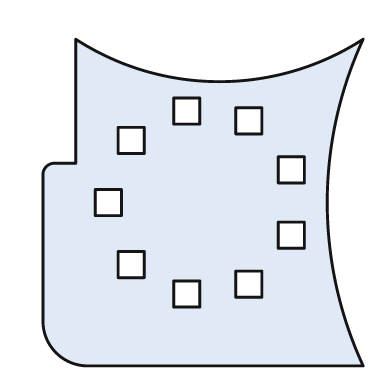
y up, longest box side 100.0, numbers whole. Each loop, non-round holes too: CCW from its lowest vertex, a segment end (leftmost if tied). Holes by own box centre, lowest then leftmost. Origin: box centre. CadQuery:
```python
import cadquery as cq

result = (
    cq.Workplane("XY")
    .moveTo(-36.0, -50.0)
    .lineTo(49.0, -50.0)
    .threePointArc((38.0, 0.0), (49.0, 50.0))
    .threePointArc((5.0, 37.0), (-39.0, 50.0))
    .lineTo(-39.0, 12.0)
    .lineTo(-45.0, 12.0)
    .threePointArc((-48.0, 11.0), (-49.0, 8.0))
    .lineTo(-49.0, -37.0)
    .threePointArc((-45.0, -46.0), (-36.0, -50.0))
    .close()
    .moveTo(-9.0, -32.0)
    .lineTo(-1.0, -32.0)
    .lineTo(-1.0, -24.0)
    .lineTo(-9.0, -24.0)
    .close()
    .moveTo(10.0, -29.0)
    .lineTo(18.0, -29.0)
    .lineTo(18.0, -21.0)
    .lineTo(10.0, -21.0)
    .close()
    .moveTo(-26.0, -23.0)
    .lineTo(-18.0, -23.0)
    .lineTo(-18.0, -15.0)
    .lineTo(-26.0, -15.0)
    .close()
    .moveTo(23.0, -14.0)
    .lineTo(31.0, -14.0)
    .lineTo(31.0, -6.0)
    .lineTo(23.0, -6.0)
    .close()
    .moveTo(-33.0, -4.0)
    .lineTo(-25.0, -4.0)
    .lineTo(-25.0, 4.0)
    .lineTo(-33.0, 4.0)
    .close()
    .moveTo(23.0, 6.0)
    .lineTo(31.0, 6.0)
    .lineTo(31.0, 14.0)
    .lineTo(23.0, 14.0)
    .close()
    .moveTo(-26.0, 15.0)
    .lineTo(-18.0, 15.0)
    .lineTo(-18.0, 23.0)
    .lineTo(-26.0, 23.0)
    .close()
    .moveTo(10.0, 21.0)
    .lineTo(18.0, 21.0)
    .lineTo(18.0, 29.0)
    .lineTo(10.0, 29.0)
    .close()
    .moveTo(-9.0, 24.0)
    .lineTo(-1.0, 24.0)
    .lineTo(-1.0, 32.0)
    .lineTo(-9.0, 32.0)
    .close()
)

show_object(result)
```